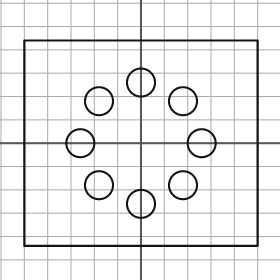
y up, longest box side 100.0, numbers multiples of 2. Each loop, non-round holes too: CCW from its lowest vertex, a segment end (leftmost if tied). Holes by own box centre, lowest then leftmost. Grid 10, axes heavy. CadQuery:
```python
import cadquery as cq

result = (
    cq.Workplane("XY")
    .moveTo(-50.0, -44.0)
    .lineTo(50.0, -44.0)
    .lineTo(50.0, 44.0)
    .lineTo(-50.0, 44.0)
    .close()
    .moveTo(0.0, -26.0)
    .circle(6.0)
    .moveTo(-18.0, -18.0)
    .circle(6.0)
    .moveTo(18.0, -18.0)
    .circle(6.0)
    .moveTo(-26.0, 0.0)
    .circle(6.0)
    .moveTo(26.0, 0.0)
    .circle(6.0)
    .moveTo(-18.0, 18.0)
    .circle(6.0)
    .moveTo(18.0, 18.0)
    .circle(6.0)
    .moveTo(0.0, 26.0)
    .circle(6.0)
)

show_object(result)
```